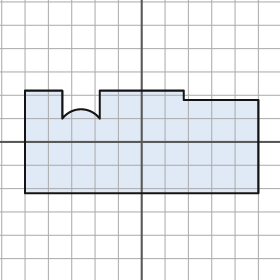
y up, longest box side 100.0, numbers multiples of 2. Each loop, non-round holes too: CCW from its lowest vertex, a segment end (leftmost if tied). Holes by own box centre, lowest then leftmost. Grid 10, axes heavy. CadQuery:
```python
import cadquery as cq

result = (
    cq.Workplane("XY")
    .moveTo(-50.0, -22.0)
    .lineTo(50.0, -22.0)
    .lineTo(50.0, 18.0)
    .lineTo(18.0, 18.0)
    .lineTo(18.0, 22.0)
    .lineTo(-18.0, 22.0)
    .lineTo(-18.0, 10.0)
    .threePointArc((-26.0, 14.0), (-34.0, 10.0))
    .lineTo(-34.0, 22.0)
    .lineTo(-50.0, 22.0)
    .close()
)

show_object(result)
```